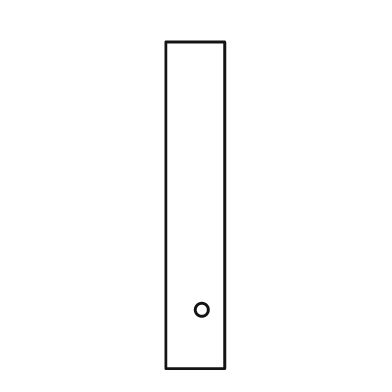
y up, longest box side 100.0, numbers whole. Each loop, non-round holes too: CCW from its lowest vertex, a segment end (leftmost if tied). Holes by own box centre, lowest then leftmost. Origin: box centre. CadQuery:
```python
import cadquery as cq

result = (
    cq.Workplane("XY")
    .moveTo(-9.0, -50.0)
    .lineTo(9.0, -50.0)
    .lineTo(9.0, 50.0)
    .lineTo(-9.0, 50.0)
    .close()
    .moveTo(2.0, -32.0)
    .circle(2.0)
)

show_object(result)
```